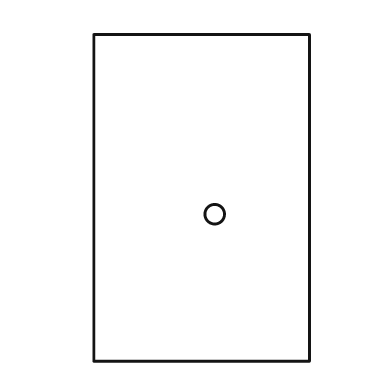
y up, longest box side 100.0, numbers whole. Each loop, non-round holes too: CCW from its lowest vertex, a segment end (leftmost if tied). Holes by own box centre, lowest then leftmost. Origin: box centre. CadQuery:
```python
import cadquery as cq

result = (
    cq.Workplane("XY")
    .moveTo(-33.0, -50.0)
    .lineTo(33.0, -50.0)
    .lineTo(33.0, 50.0)
    .lineTo(-33.0, 50.0)
    .close()
    .moveTo(4.0, -5.0)
    .circle(3.0)
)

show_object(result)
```